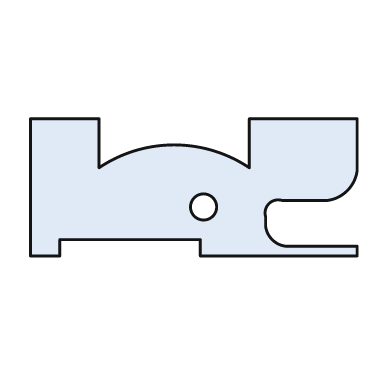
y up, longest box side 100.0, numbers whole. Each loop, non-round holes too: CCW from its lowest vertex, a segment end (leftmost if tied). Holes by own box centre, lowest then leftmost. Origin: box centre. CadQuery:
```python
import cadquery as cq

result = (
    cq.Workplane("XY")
    .moveTo(-50.0, -21.0)
    .lineTo(-41.0, -21.0)
    .lineTo(-41.0, -16.0)
    .lineTo(2.0, -16.0)
    .lineTo(2.0, -21.0)
    .lineTo(50.0, -21.0)
    .lineTo(50.0, -18.0)
    .lineTo(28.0, -18.0)
    .threePointArc((24.0, -16.0), (22.0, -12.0))
    .lineTo(22.0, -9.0)
    .threePointArc((23.0, -5.0), (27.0, -4.0))
    .lineTo(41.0, -4.0)
    .threePointArc((47.0, -1.0), (50.0, 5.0))
    .lineTo(50.0, 21.0)
    .lineTo(17.0, 21.0)
    .lineTo(17.0, 6.0)
    .threePointArc((-6.0, 13.0), (-29.0, 6.0))
    .lineTo(-29.0, 21.0)
    .lineTo(-50.0, 21.0)
    .close()
    .moveTo(3.0, -6.0)
    .circle(4.0)
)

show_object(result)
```